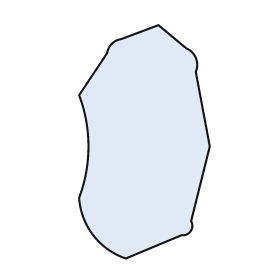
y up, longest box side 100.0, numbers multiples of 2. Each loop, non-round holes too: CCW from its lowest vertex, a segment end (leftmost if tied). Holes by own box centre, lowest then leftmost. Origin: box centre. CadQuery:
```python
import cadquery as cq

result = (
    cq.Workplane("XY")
    .moveTo(-8.0, -50.0)
    .lineTo(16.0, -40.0)
    .threePointArc((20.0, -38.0), (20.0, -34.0))
    .lineTo(28.0, -2.0)
    .lineTo(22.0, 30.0)
    .threePointArc((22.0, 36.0), (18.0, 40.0))
    .lineTo(6.0, 50.0)
    .lineTo(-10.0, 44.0)
    .threePointArc((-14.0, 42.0), (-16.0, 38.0))
    .lineTo(-28.0, 20.0)
    .threePointArc((-24.0, -2.0), (-28.0, -24.0))
    .threePointArc((-22.0, -40.0), (-8.0, -50.0))
    .close()
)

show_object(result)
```